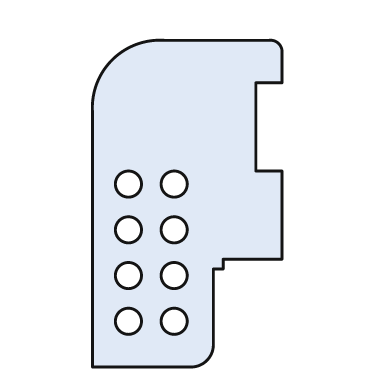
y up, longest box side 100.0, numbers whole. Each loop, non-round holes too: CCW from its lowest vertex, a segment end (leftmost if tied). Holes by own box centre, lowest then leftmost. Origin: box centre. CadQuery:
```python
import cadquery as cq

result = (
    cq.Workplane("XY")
    .moveTo(-29.0, -50.0)
    .lineTo(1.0, -50.0)
    .threePointArc((6.0, -48.0), (8.0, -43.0))
    .lineTo(8.0, -20.0)
    .lineTo(11.0, -20.0)
    .lineTo(11.0, -17.0)
    .lineTo(29.0, -17.0)
    .lineTo(29.0, 10.0)
    .lineTo(21.0, 10.0)
    .lineTo(21.0, 37.0)
    .lineTo(29.0, 37.0)
    .lineTo(29.0, 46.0)
    .threePointArc((28.0, 49.0), (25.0, 50.0))
    .lineTo(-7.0, 50.0)
    .threePointArc((-23.0, 44.0), (-29.0, 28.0))
    .close()
    .moveTo(-18.0, -36.0)
    .circle(4.0)
    .moveTo(-4.0, -36.0)
    .circle(4.0)
    .moveTo(-18.0, -22.0)
    .circle(4.0)
    .moveTo(-4.0, -22.0)
    .circle(4.0)
    .moveTo(-18.0, -8.0)
    .circle(4.0)
    .moveTo(-4.0, -8.0)
    .circle(4.0)
    .moveTo(-18.0, 6.0)
    .circle(4.0)
    .moveTo(-4.0, 6.0)
    .circle(4.0)
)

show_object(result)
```